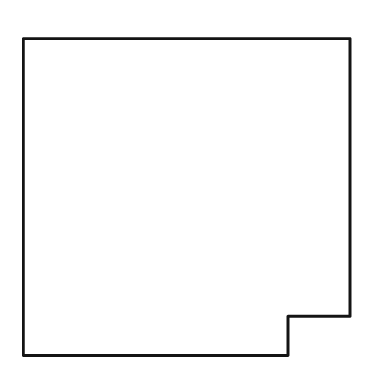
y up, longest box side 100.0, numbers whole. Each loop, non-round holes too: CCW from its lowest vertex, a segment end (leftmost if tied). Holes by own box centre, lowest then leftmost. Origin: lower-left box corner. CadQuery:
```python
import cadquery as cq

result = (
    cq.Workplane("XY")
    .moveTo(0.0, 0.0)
    .lineTo(81.0, 0.0)
    .lineTo(81.0, 12.0)
    .lineTo(100.0, 12.0)
    .lineTo(100.0, 97.0)
    .lineTo(0.0, 97.0)
    .close()
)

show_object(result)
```